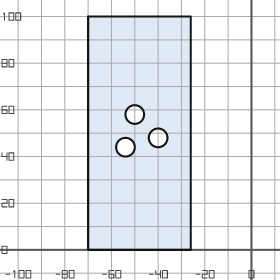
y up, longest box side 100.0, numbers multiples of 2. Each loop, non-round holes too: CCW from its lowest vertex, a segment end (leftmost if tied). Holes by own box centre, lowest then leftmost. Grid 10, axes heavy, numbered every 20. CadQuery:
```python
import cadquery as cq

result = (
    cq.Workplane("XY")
    .moveTo(-70.0, 0.0)
    .lineTo(-26.0, 0.0)
    .lineTo(-26.0, 100.0)
    .lineTo(-70.0, 100.0)
    .close()
    .moveTo(-54.0, 44.0)
    .circle(4.0)
    .moveTo(-40.0, 48.0)
    .circle(4.0)
    .moveTo(-50.0, 58.0)
    .circle(4.0)
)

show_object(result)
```